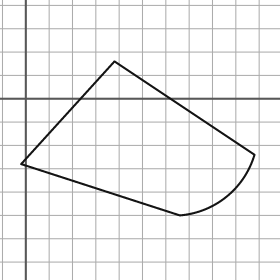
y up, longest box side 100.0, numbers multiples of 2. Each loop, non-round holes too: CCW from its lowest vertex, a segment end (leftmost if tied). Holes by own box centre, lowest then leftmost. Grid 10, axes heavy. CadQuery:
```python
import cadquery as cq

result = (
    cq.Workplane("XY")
    .moveTo(66.0, -50.0)
    .threePointArc((86.0, -42.0), (98.0, -24.0))
    .lineTo(38.0, 16.0)
    .lineTo(-2.0, -28.0)
    .close()
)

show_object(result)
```